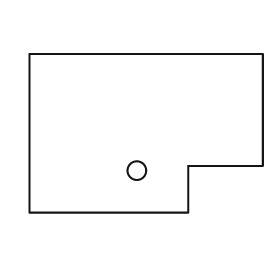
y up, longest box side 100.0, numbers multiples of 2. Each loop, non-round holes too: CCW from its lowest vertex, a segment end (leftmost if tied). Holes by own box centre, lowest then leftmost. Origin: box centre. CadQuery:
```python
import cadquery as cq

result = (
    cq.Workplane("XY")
    .moveTo(-50.0, -34.0)
    .lineTo(18.0, -34.0)
    .lineTo(18.0, -14.0)
    .lineTo(50.0, -14.0)
    .lineTo(50.0, 34.0)
    .lineTo(-50.0, 34.0)
    .close()
    .moveTo(-4.0, -16.0)
    .circle(4.0)
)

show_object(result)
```